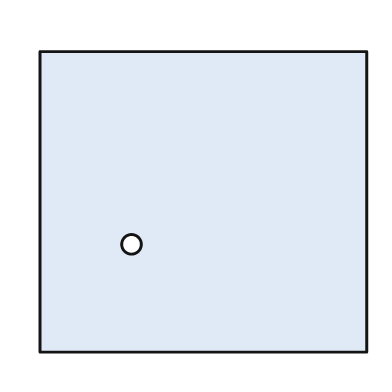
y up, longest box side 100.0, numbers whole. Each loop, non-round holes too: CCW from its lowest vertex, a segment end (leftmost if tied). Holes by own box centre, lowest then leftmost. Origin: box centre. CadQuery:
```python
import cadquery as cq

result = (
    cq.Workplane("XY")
    .moveTo(-50.0, -46.0)
    .lineTo(50.0, -46.0)
    .lineTo(50.0, 46.0)
    .lineTo(-50.0, 46.0)
    .close()
    .moveTo(-22.0, -13.0)
    .circle(3.0)
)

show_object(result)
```